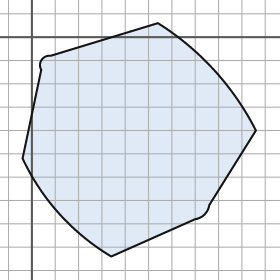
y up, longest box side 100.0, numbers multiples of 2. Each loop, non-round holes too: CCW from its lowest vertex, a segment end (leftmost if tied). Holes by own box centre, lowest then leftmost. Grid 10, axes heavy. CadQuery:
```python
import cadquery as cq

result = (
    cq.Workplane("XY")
    .moveTo(34.0, -94.0)
    .lineTo(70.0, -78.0)
    .threePointArc((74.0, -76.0), (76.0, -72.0))
    .lineTo(96.0, -40.0)
    .threePointArc((78.0, -14.0), (54.0, 6.0))
    .lineTo(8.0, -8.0)
    .threePointArc((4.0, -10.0), (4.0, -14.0))
    .lineTo(-4.0, -52.0)
    .threePointArc((12.0, -76.0), (34.0, -94.0))
    .close()
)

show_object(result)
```